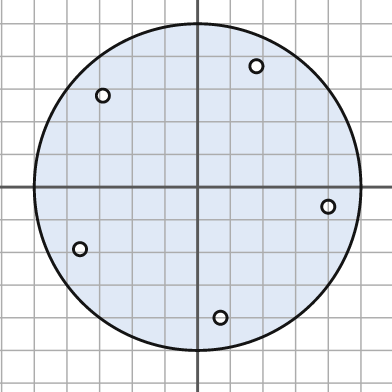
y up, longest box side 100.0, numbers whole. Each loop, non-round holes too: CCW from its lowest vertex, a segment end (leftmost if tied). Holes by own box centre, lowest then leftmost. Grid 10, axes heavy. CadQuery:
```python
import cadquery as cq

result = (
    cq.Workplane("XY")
    .moveTo(0.0, 0.0)
    .circle(50.0)
    .moveTo(7.0, -40.0)
    .circle(2.0)
    .moveTo(-36.0, -19.0)
    .circle(2.0)
    .moveTo(40.0, -6.0)
    .circle(2.0)
    .moveTo(-29.0, 28.0)
    .circle(2.0)
    .moveTo(18.0, 37.0)
    .circle(2.0)
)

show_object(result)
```